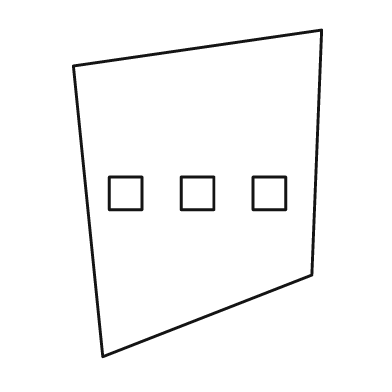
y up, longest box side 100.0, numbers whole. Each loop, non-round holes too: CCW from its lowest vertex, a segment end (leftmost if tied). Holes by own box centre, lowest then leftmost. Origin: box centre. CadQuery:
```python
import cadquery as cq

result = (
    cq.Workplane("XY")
    .moveTo(-29.0, -50.0)
    .lineTo(35.0, -25.0)
    .lineTo(38.0, 50.0)
    .lineTo(-38.0, 39.0)
    .close()
    .moveTo(-27.0, -5.0)
    .lineTo(-17.0, -5.0)
    .lineTo(-17.0, 5.0)
    .lineTo(-27.0, 5.0)
    .close()
    .moveTo(-5.0, -5.0)
    .lineTo(5.0, -5.0)
    .lineTo(5.0, 5.0)
    .lineTo(-5.0, 5.0)
    .close()
    .moveTo(17.0, -5.0)
    .lineTo(27.0, -5.0)
    .lineTo(27.0, 5.0)
    .lineTo(17.0, 5.0)
    .close()
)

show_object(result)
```